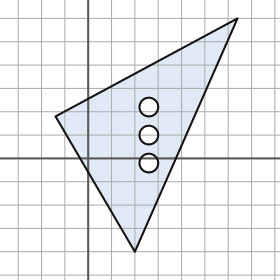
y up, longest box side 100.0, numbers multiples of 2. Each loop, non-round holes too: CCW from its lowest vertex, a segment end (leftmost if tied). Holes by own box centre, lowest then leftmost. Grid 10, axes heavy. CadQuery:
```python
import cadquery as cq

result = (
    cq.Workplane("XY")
    .moveTo(20.0, -40.0)
    .lineTo(64.0, 60.0)
    .lineTo(-14.0, 18.0)
    .close()
    .moveTo(26.0, -2.0)
    .circle(4.0)
    .moveTo(26.0, 10.0)
    .circle(4.0)
    .moveTo(26.0, 22.0)
    .circle(4.0)
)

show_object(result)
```